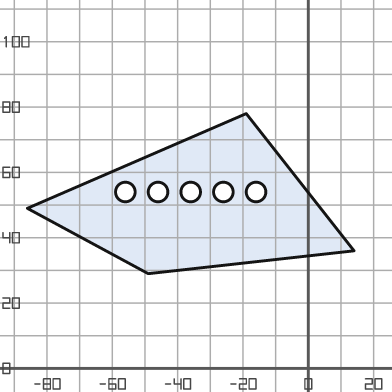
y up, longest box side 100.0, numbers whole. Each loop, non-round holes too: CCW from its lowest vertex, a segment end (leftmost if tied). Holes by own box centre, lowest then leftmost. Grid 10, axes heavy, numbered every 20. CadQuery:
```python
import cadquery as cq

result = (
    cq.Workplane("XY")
    .moveTo(-49.0, 29.0)
    .lineTo(14.0, 36.0)
    .lineTo(-19.0, 78.0)
    .lineTo(-86.0, 49.0)
    .close()
    .moveTo(-56.0, 54.0)
    .circle(3.0)
    .moveTo(-46.0, 54.0)
    .circle(3.0)
    .moveTo(-36.0, 54.0)
    .circle(3.0)
    .moveTo(-26.0, 54.0)
    .circle(3.0)
    .moveTo(-16.0, 54.0)
    .circle(3.0)
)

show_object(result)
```